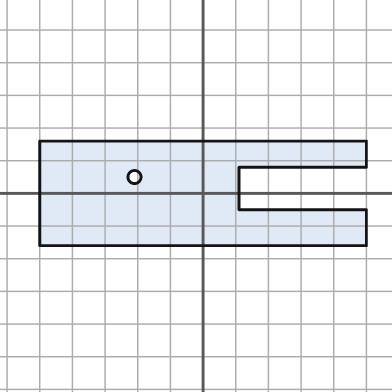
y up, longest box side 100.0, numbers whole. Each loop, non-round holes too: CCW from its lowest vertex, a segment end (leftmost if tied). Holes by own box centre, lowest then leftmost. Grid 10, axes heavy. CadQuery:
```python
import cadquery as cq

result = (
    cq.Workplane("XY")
    .moveTo(-50.0, -16.0)
    .lineTo(50.0, -16.0)
    .lineTo(50.0, -5.0)
    .lineTo(11.0, -5.0)
    .lineTo(11.0, 8.0)
    .lineTo(50.0, 8.0)
    .lineTo(50.0, 16.0)
    .lineTo(-50.0, 16.0)
    .close()
    .moveTo(-21.0, 5.0)
    .circle(2.0)
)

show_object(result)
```